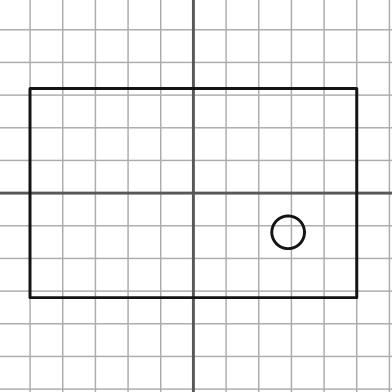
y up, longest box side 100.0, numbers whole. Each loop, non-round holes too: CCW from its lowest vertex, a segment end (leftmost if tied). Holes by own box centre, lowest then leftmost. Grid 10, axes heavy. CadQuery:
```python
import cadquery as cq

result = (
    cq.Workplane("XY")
    .moveTo(-50.0, -32.0)
    .lineTo(50.0, -32.0)
    .lineTo(50.0, 32.0)
    .lineTo(-50.0, 32.0)
    .close()
    .moveTo(29.0, -12.0)
    .circle(5.0)
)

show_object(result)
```